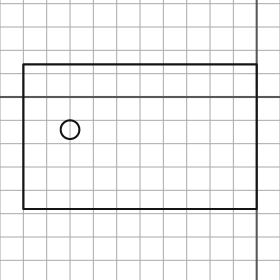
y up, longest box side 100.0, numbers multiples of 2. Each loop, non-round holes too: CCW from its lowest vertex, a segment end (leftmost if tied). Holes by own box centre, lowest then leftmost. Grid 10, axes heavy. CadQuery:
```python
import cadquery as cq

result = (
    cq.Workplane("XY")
    .moveTo(-100.0, -48.0)
    .lineTo(0.0, -48.0)
    .lineTo(0.0, 14.0)
    .lineTo(-100.0, 14.0)
    .close()
    .moveTo(-80.0, -14.0)
    .circle(4.0)
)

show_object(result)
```